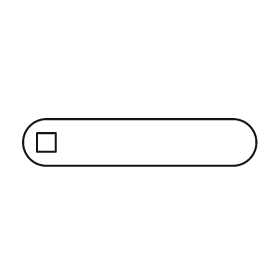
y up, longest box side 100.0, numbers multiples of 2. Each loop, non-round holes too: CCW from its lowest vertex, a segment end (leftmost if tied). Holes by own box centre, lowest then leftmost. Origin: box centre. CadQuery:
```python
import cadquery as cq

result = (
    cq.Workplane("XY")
    .moveTo(-40.0, -10.0)
    .lineTo(40.0, -10.0)
    .threePointArc((50.0, 0.0), (40.0, 10.0))
    .lineTo(-40.0, 10.0)
    .threePointArc((-50.0, 0.0), (-40.0, -10.0))
    .close()
    .moveTo(-44.0, -4.0)
    .lineTo(-36.0, -4.0)
    .lineTo(-36.0, 4.0)
    .lineTo(-44.0, 4.0)
    .close()
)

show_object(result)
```